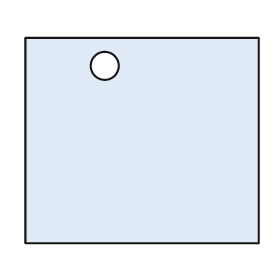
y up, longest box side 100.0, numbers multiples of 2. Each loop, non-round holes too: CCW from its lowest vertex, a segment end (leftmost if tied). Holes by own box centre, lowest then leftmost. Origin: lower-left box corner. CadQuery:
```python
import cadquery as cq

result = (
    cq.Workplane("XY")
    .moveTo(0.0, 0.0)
    .lineTo(100.0, 0.0)
    .lineTo(100.0, 88.0)
    .lineTo(0.0, 88.0)
    .close()
    .moveTo(34.0, 76.0)
    .circle(6.0)
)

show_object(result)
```